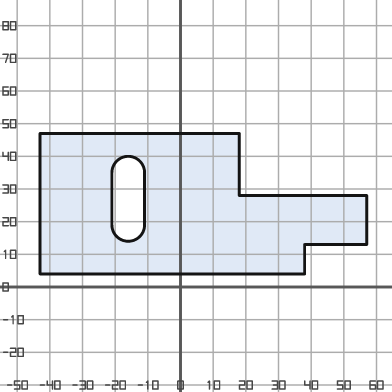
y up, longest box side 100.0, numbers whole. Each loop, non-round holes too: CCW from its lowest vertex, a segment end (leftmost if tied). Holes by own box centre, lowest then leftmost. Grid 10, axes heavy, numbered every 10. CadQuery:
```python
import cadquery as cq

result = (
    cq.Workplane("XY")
    .moveTo(-43.0, 4.0)
    .lineTo(38.0, 4.0)
    .lineTo(38.0, 13.0)
    .lineTo(57.0, 13.0)
    .lineTo(57.0, 28.0)
    .lineTo(18.0, 28.0)
    .lineTo(18.0, 47.0)
    .lineTo(-43.0, 47.0)
    .close()
    .moveTo(-21.0, 19.0)
    .threePointArc((-16.0, 14.0), (-11.0, 19.0))
    .lineTo(-11.0, 35.0)
    .threePointArc((-16.0, 40.0), (-21.0, 35.0))
    .close()
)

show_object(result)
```